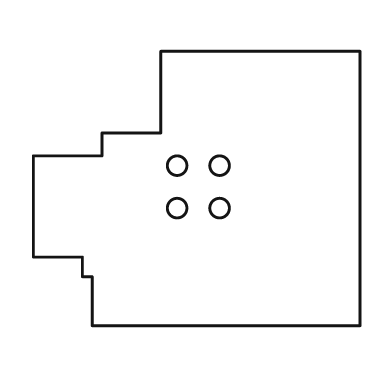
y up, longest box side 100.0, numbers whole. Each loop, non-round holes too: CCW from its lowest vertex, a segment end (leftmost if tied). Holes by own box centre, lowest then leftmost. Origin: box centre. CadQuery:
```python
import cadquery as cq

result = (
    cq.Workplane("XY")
    .moveTo(-32.0, -42.0)
    .lineTo(50.0, -42.0)
    .lineTo(50.0, 42.0)
    .lineTo(-11.0, 42.0)
    .lineTo(-11.0, 17.0)
    .lineTo(-29.0, 17.0)
    .lineTo(-29.0, 10.0)
    .lineTo(-50.0, 10.0)
    .lineTo(-50.0, -21.0)
    .lineTo(-35.0, -21.0)
    .lineTo(-35.0, -27.0)
    .lineTo(-32.0, -27.0)
    .close()
    .moveTo(-6.0, -6.0)
    .circle(3.0)
    .moveTo(7.0, -6.0)
    .circle(3.0)
    .moveTo(-6.0, 7.0)
    .circle(3.0)
    .moveTo(7.0, 7.0)
    .circle(3.0)
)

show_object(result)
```